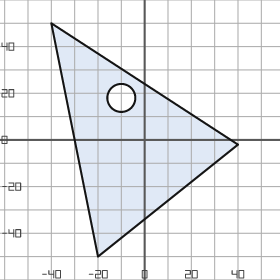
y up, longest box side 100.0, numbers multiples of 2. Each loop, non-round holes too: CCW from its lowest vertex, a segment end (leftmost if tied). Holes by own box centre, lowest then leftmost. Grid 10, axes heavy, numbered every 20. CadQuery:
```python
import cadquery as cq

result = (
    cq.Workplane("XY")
    .moveTo(-20.0, -50.0)
    .lineTo(40.0, -2.0)
    .lineTo(-40.0, 50.0)
    .close()
    .moveTo(-10.0, 18.0)
    .circle(6.0)
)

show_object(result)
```